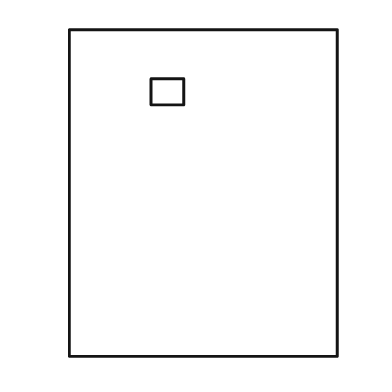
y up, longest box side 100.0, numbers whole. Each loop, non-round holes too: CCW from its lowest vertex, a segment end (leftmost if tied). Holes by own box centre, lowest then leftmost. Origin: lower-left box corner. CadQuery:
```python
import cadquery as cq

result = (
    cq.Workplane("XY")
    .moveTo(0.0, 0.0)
    .lineTo(82.0, 0.0)
    .lineTo(82.0, 100.0)
    .lineTo(0.0, 100.0)
    .close()
    .moveTo(25.0, 77.0)
    .lineTo(35.0, 77.0)
    .lineTo(35.0, 85.0)
    .lineTo(25.0, 85.0)
    .close()
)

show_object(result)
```